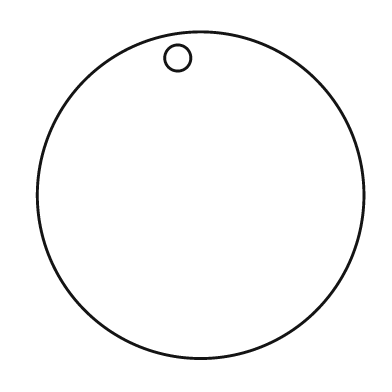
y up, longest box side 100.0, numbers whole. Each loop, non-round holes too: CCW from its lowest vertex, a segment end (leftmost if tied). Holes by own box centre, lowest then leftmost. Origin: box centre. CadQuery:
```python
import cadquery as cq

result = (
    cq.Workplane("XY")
    .moveTo(0.0, 0.0)
    .circle(50.0)
    .moveTo(-7.0, 42.0)
    .circle(4.0)
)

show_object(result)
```